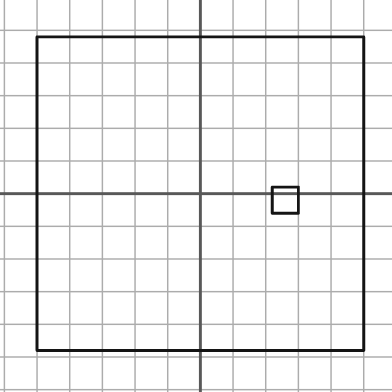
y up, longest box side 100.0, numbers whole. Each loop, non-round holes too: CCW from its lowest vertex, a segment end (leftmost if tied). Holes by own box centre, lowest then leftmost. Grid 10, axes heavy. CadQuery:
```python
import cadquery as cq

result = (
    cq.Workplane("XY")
    .moveTo(-50.0, -48.0)
    .lineTo(50.0, -48.0)
    .lineTo(50.0, 48.0)
    .lineTo(-50.0, 48.0)
    .close()
    .moveTo(22.0, -6.0)
    .lineTo(30.0, -6.0)
    .lineTo(30.0, 2.0)
    .lineTo(22.0, 2.0)
    .close()
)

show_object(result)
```